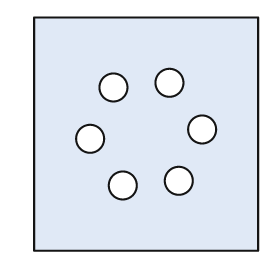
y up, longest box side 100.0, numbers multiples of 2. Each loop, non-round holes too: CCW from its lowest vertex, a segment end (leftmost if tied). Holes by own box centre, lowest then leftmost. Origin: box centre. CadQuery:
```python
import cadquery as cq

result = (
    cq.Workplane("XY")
    .moveTo(-48.0, -50.0)
    .lineTo(48.0, -50.0)
    .lineTo(48.0, 50.0)
    .lineTo(-48.0, 50.0)
    .close()
    .moveTo(-10.0, -22.0)
    .circle(6.0)
    .moveTo(14.0, -20.0)
    .circle(6.0)
    .moveTo(-24.0, -2.0)
    .circle(6.0)
    .moveTo(24.0, 2.0)
    .circle(6.0)
    .moveTo(-14.0, 20.0)
    .circle(6.0)
    .moveTo(10.0, 22.0)
    .circle(6.0)
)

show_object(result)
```